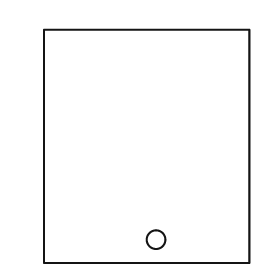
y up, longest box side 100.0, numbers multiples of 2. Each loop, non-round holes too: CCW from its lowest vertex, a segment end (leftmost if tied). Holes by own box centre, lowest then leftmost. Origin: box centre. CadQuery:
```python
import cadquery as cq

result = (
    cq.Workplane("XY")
    .moveTo(-44.0, -50.0)
    .lineTo(44.0, -50.0)
    .lineTo(44.0, 50.0)
    .lineTo(-44.0, 50.0)
    .close()
    .moveTo(4.0, -40.0)
    .circle(4.0)
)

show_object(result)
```